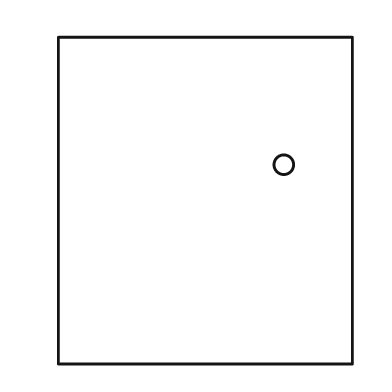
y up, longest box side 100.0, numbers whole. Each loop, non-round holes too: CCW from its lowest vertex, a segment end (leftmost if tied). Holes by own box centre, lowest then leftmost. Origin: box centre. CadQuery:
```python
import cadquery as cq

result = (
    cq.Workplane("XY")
    .moveTo(-45.0, -50.0)
    .lineTo(45.0, -50.0)
    .lineTo(45.0, 50.0)
    .lineTo(-45.0, 50.0)
    .close()
    .moveTo(24.0, 11.0)
    .circle(3.0)
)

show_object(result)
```